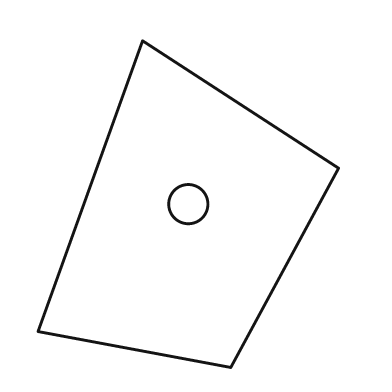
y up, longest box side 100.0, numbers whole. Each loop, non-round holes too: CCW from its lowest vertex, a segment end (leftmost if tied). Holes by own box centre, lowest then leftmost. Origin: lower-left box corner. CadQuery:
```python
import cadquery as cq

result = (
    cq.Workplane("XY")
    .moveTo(59.0, 0.0)
    .lineTo(92.0, 61.0)
    .lineTo(32.0, 100.0)
    .lineTo(0.0, 11.0)
    .close()
    .moveTo(46.0, 50.0)
    .circle(6.0)
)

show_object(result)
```